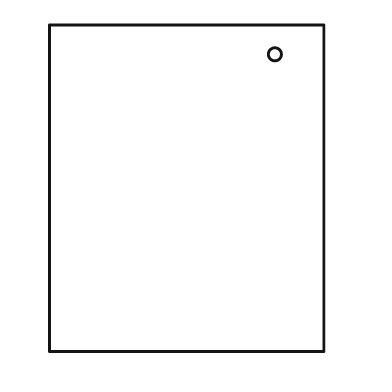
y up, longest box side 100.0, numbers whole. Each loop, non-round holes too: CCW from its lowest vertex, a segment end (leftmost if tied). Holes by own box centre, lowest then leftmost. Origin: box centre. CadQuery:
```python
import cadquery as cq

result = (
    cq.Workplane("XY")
    .moveTo(-42.0, -50.0)
    .lineTo(42.0, -50.0)
    .lineTo(42.0, 50.0)
    .lineTo(-42.0, 50.0)
    .close()
    .moveTo(27.0, 41.0)
    .circle(2.0)
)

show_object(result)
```